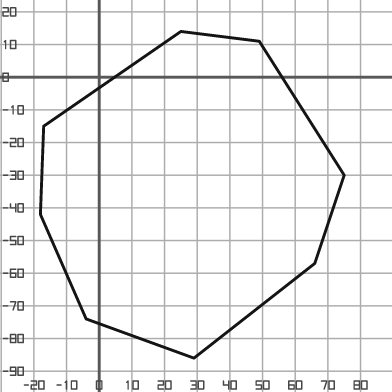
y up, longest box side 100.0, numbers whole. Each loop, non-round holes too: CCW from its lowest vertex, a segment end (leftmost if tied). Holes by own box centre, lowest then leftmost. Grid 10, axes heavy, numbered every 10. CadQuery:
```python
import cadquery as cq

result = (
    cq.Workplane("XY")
    .moveTo(29.0, -86.0)
    .lineTo(66.0, -57.0)
    .lineTo(75.0, -30.0)
    .lineTo(49.0, 11.0)
    .lineTo(25.0, 14.0)
    .lineTo(-17.0, -15.0)
    .lineTo(-18.0, -42.0)
    .lineTo(-4.0, -74.0)
    .close()
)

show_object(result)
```